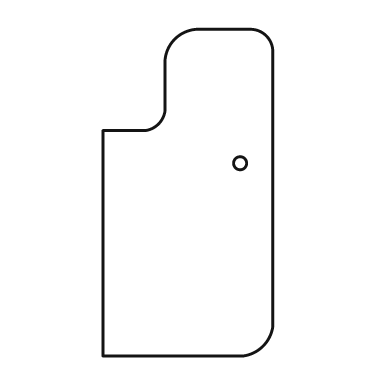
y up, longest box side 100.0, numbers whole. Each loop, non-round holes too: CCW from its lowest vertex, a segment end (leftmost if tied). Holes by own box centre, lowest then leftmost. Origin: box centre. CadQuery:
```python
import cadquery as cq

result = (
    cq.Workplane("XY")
    .moveTo(-26.0, -50.0)
    .lineTo(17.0, -50.0)
    .threePointArc((23.0, -47.0), (26.0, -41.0))
    .lineTo(26.0, 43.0)
    .threePointArc((24.0, 48.0), (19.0, 50.0))
    .lineTo(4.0, 50.0)
    .threePointArc((-4.0, 47.0), (-7.0, 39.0))
    .lineTo(-7.0, 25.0)
    .threePointArc((-9.0, 21.0), (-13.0, 19.0))
    .lineTo(-26.0, 19.0)
    .close()
    .moveTo(16.0, 9.0)
    .circle(2.0)
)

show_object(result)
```